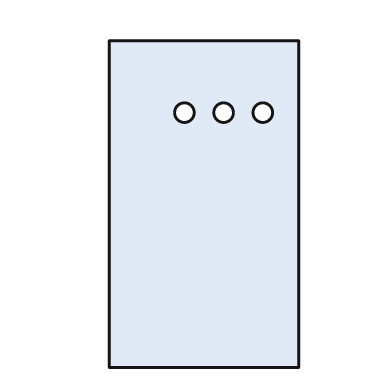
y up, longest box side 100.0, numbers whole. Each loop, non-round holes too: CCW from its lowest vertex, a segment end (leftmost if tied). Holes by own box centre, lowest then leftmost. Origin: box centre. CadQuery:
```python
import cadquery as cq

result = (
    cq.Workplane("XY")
    .moveTo(-29.0, -50.0)
    .lineTo(29.0, -50.0)
    .lineTo(29.0, 50.0)
    .lineTo(-29.0, 50.0)
    .close()
    .moveTo(-6.0, 28.0)
    .circle(3.0)
    .moveTo(6.0, 28.0)
    .circle(3.0)
    .moveTo(18.0, 28.0)
    .circle(3.0)
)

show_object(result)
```